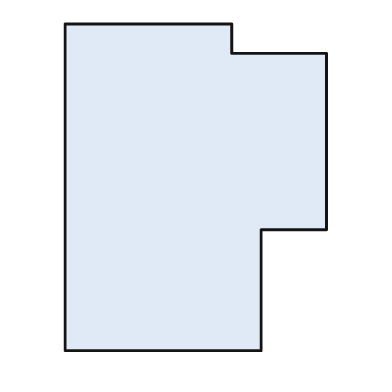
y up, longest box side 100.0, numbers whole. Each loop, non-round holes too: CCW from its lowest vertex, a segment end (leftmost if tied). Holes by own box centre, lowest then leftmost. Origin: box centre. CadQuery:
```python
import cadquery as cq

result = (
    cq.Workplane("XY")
    .moveTo(-40.0, -50.0)
    .lineTo(20.0, -50.0)
    .lineTo(20.0, -13.0)
    .lineTo(40.0, -13.0)
    .lineTo(40.0, 41.0)
    .lineTo(11.0, 41.0)
    .lineTo(11.0, 50.0)
    .lineTo(-40.0, 50.0)
    .close()
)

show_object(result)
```